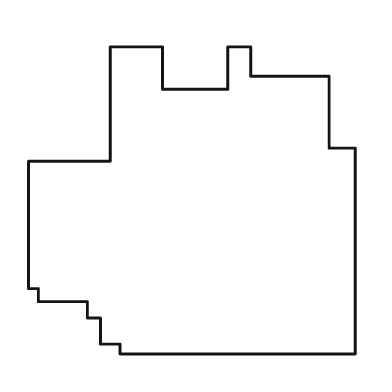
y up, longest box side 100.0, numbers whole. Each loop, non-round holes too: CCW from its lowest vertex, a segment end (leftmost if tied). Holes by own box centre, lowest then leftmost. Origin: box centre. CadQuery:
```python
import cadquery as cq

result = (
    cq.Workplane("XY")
    .moveTo(-22.0, -47.0)
    .lineTo(50.0, -47.0)
    .lineTo(50.0, 16.0)
    .lineTo(42.0, 16.0)
    .lineTo(42.0, 38.0)
    .lineTo(18.0, 38.0)
    .lineTo(18.0, 47.0)
    .lineTo(11.0, 47.0)
    .lineTo(11.0, 34.0)
    .lineTo(-9.0, 34.0)
    .lineTo(-9.0, 47.0)
    .lineTo(-25.0, 47.0)
    .lineTo(-25.0, 12.0)
    .lineTo(-50.0, 12.0)
    .lineTo(-50.0, -27.0)
    .lineTo(-47.0, -27.0)
    .lineTo(-47.0, -31.0)
    .lineTo(-32.0, -31.0)
    .lineTo(-32.0, -36.0)
    .lineTo(-28.0, -36.0)
    .lineTo(-28.0, -44.0)
    .lineTo(-22.0, -44.0)
    .close()
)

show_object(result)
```